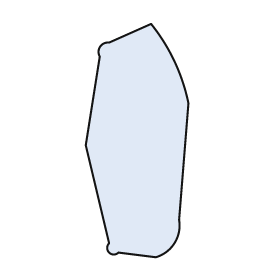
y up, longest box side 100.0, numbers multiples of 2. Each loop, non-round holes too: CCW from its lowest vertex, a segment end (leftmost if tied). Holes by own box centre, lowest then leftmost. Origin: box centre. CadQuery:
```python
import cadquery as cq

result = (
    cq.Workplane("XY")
    .moveTo(8.0, -50.0)
    .threePointArc((16.0, -44.0), (18.0, -34.0))
    .lineTo(22.0, 16.0)
    .threePointArc((16.0, 34.0), (6.0, 50.0))
    .lineTo(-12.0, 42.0)
    .threePointArc((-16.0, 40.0), (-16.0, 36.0))
    .lineTo(-22.0, -2.0)
    .lineTo(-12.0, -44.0)
    .threePointArc((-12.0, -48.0), (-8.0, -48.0))
    .close()
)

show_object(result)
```